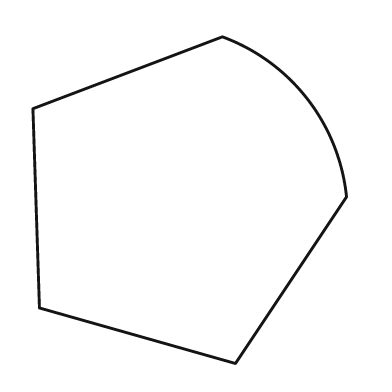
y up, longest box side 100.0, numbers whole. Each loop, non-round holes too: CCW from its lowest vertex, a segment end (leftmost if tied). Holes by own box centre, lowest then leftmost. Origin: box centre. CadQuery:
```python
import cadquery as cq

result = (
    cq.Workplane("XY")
    .moveTo(14.0, -50.0)
    .lineTo(48.0, 1.0)
    .threePointArc((36.0, 31.0), (10.0, 50.0))
    .lineTo(-48.0, 28.0)
    .lineTo(-46.0, -33.0)
    .close()
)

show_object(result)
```